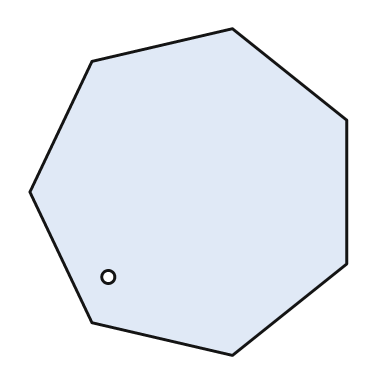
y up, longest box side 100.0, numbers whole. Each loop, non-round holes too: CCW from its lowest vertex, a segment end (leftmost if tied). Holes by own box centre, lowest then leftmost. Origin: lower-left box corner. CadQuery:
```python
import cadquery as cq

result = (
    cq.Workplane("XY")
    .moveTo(62.0, 0.0)
    .lineTo(97.0, 28.0)
    .lineTo(97.0, 72.0)
    .lineTo(62.0, 100.0)
    .lineTo(19.0, 90.0)
    .lineTo(0.0, 50.0)
    .lineTo(19.0, 10.0)
    .close()
    .moveTo(24.0, 24.0)
    .circle(2.0)
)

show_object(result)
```